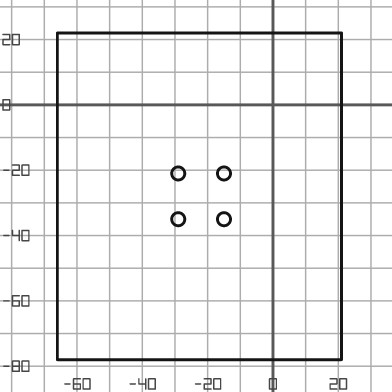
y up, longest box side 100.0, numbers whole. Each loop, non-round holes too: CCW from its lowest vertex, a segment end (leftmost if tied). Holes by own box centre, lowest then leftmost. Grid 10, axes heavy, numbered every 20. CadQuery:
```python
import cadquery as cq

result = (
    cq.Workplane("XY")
    .moveTo(-66.0, -78.0)
    .lineTo(21.0, -78.0)
    .lineTo(21.0, 22.0)
    .lineTo(-66.0, 22.0)
    .close()
    .moveTo(-29.0, -35.0)
    .circle(2.0)
    .moveTo(-15.0, -35.0)
    .circle(2.0)
    .moveTo(-29.0, -21.0)
    .circle(2.0)
    .moveTo(-15.0, -21.0)
    .circle(2.0)
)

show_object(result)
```